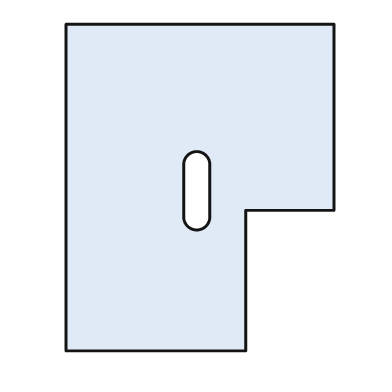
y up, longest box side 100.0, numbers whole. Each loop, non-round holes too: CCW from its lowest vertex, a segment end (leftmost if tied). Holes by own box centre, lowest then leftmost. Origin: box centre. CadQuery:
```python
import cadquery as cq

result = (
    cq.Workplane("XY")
    .moveTo(-41.0, -50.0)
    .lineTo(14.0, -50.0)
    .lineTo(14.0, -7.0)
    .lineTo(41.0, -7.0)
    .lineTo(41.0, 50.0)
    .lineTo(-41.0, 50.0)
    .close()
    .moveTo(-5.0, -9.0)
    .threePointArc((-1.0, -13.0), (3.0, -9.0))
    .lineTo(3.0, 7.0)
    .threePointArc((-1.0, 11.0), (-5.0, 7.0))
    .close()
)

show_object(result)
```